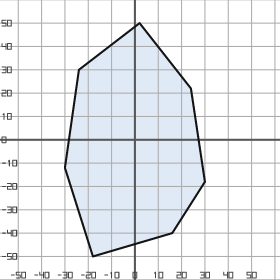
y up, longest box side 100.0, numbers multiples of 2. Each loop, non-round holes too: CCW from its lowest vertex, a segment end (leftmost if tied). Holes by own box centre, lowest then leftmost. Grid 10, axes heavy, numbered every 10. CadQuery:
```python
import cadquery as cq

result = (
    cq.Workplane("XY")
    .moveTo(-18.0, -50.0)
    .lineTo(16.0, -40.0)
    .lineTo(30.0, -18.0)
    .lineTo(24.0, 22.0)
    .lineTo(2.0, 50.0)
    .lineTo(-24.0, 30.0)
    .lineTo(-30.0, -12.0)
    .close()
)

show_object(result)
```